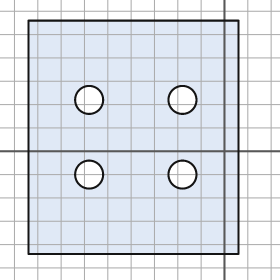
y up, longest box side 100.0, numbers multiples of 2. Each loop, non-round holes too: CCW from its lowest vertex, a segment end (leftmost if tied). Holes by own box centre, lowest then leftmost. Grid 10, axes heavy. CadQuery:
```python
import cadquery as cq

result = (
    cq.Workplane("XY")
    .moveTo(-84.0, -44.0)
    .lineTo(6.0, -44.0)
    .lineTo(6.0, 56.0)
    .lineTo(-84.0, 56.0)
    .close()
    .moveTo(-58.0, -10.0)
    .circle(6.0)
    .moveTo(-18.0, -10.0)
    .circle(6.0)
    .moveTo(-58.0, 22.0)
    .circle(6.0)
    .moveTo(-18.0, 22.0)
    .circle(6.0)
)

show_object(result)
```